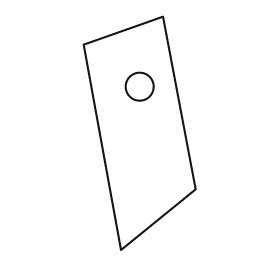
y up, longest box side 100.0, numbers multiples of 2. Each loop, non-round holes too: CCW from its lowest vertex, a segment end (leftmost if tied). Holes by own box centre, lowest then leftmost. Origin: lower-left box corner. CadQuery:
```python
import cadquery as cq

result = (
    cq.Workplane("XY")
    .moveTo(16.0, 0.0)
    .lineTo(48.0, 26.0)
    .lineTo(34.0, 100.0)
    .lineTo(0.0, 88.0)
    .close()
    .moveTo(24.0, 70.0)
    .circle(6.0)
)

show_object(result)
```